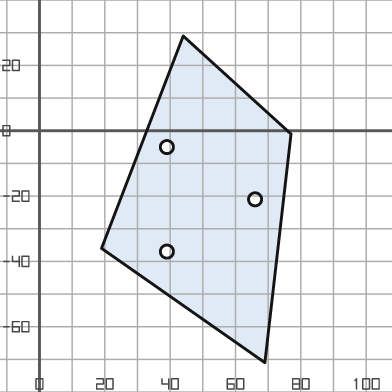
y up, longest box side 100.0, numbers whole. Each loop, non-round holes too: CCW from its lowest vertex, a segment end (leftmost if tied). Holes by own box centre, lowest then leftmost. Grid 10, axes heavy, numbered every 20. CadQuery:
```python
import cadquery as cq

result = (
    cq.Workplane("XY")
    .moveTo(69.0, -71.0)
    .lineTo(77.0, -1.0)
    .lineTo(44.0, 29.0)
    .lineTo(19.0, -36.0)
    .close()
    .moveTo(39.0, -37.0)
    .circle(2.0)
    .moveTo(66.0, -21.0)
    .circle(2.0)
    .moveTo(39.0, -5.0)
    .circle(2.0)
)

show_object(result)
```